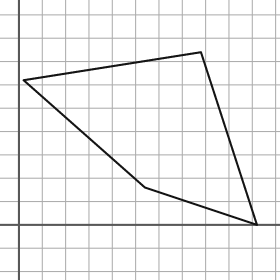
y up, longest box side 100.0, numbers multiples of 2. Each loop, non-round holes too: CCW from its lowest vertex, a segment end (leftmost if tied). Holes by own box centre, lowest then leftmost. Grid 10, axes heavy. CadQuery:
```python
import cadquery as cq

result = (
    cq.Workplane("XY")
    .moveTo(102.0, 0.0)
    .lineTo(78.0, 74.0)
    .lineTo(2.0, 62.0)
    .lineTo(54.0, 16.0)
    .close()
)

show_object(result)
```